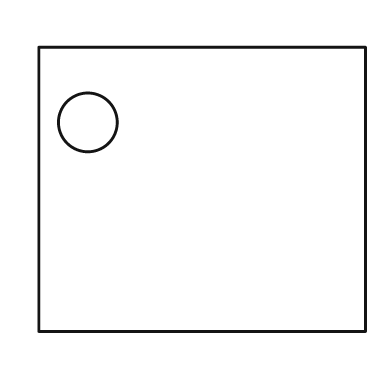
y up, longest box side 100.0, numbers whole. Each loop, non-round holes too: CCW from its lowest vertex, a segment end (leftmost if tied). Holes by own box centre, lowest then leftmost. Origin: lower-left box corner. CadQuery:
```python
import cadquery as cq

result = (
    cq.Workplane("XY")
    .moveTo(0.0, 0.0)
    .lineTo(100.0, 0.0)
    .lineTo(100.0, 87.0)
    .lineTo(0.0, 87.0)
    .close()
    .moveTo(15.0, 64.0)
    .circle(9.0)
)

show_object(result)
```